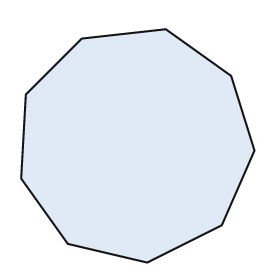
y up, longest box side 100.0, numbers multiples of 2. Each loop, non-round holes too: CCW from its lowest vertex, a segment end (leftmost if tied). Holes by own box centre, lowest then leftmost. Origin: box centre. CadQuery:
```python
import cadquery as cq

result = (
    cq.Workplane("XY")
    .moveTo(4.0, -50.0)
    .lineTo(36.0, -34.0)
    .lineTo(50.0, -2.0)
    .lineTo(40.0, 30.0)
    .lineTo(12.0, 50.0)
    .lineTo(-24.0, 46.0)
    .lineTo(-48.0, 22.0)
    .lineTo(-50.0, -14.0)
    .lineTo(-30.0, -42.0)
    .close()
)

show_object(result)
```